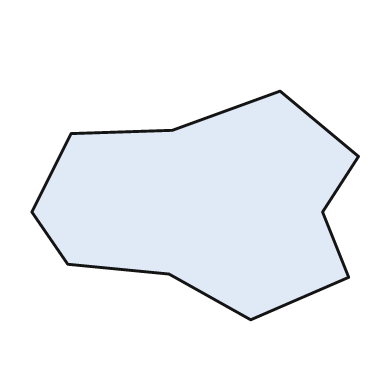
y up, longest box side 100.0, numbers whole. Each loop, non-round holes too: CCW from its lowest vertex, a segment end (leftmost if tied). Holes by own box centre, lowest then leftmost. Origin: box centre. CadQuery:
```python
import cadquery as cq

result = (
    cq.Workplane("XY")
    .moveTo(17.0, -35.0)
    .lineTo(47.0, -22.0)
    .lineTo(39.0, -2.0)
    .lineTo(50.0, 15.0)
    .lineTo(26.0, 35.0)
    .lineTo(-7.0, 23.0)
    .lineTo(-38.0, 22.0)
    .lineTo(-50.0, -2.0)
    .lineTo(-39.0, -18.0)
    .lineTo(-8.0, -21.0)
    .close()
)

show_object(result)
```